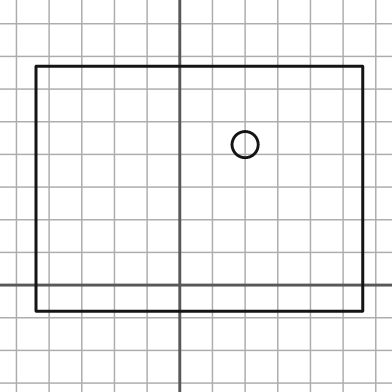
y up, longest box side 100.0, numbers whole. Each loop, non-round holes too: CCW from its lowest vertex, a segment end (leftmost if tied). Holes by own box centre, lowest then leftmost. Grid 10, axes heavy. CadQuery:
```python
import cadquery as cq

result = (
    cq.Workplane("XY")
    .moveTo(-44.0, -8.0)
    .lineTo(56.0, -8.0)
    .lineTo(56.0, 67.0)
    .lineTo(-44.0, 67.0)
    .close()
    .moveTo(20.0, 43.0)
    .circle(4.0)
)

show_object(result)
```